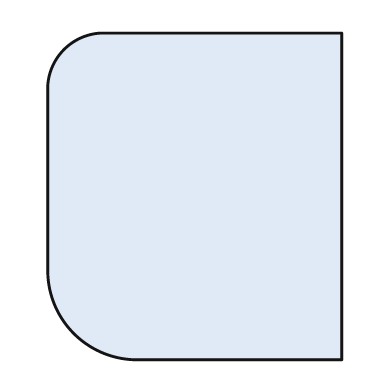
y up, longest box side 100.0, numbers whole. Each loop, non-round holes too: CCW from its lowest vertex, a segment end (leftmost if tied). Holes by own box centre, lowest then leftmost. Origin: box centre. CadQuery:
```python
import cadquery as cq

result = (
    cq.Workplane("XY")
    .moveTo(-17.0, -50.0)
    .lineTo(45.0, -50.0)
    .lineTo(45.0, 50.0)
    .lineTo(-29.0, 50.0)
    .threePointArc((-40.0, 45.0), (-45.0, 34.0))
    .lineTo(-45.0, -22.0)
    .threePointArc((-37.0, -42.0), (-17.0, -50.0))
    .close()
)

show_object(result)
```